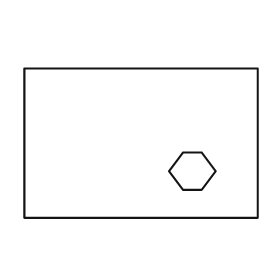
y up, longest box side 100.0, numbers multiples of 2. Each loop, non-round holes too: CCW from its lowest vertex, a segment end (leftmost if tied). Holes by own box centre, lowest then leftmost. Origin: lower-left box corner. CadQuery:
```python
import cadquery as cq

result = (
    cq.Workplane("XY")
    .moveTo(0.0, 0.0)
    .lineTo(100.0, 0.0)
    .lineTo(100.0, 64.0)
    .lineTo(0.0, 64.0)
    .close()
    .moveTo(68.0, 12.0)
    .lineTo(76.0, 12.0)
    .lineTo(82.0, 20.0)
    .lineTo(76.0, 28.0)
    .lineTo(68.0, 28.0)
    .lineTo(62.0, 20.0)
    .close()
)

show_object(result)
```